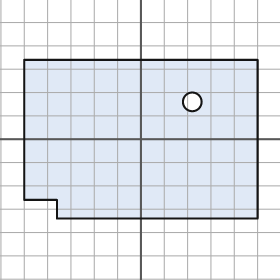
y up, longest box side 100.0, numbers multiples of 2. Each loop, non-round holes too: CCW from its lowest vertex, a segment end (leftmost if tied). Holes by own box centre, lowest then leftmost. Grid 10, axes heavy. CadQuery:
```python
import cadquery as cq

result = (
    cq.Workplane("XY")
    .moveTo(-36.0, -34.0)
    .lineTo(50.0, -34.0)
    .lineTo(50.0, 34.0)
    .lineTo(-50.0, 34.0)
    .lineTo(-50.0, -26.0)
    .lineTo(-36.0, -26.0)
    .close()
    .moveTo(22.0, 16.0)
    .circle(4.0)
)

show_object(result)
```